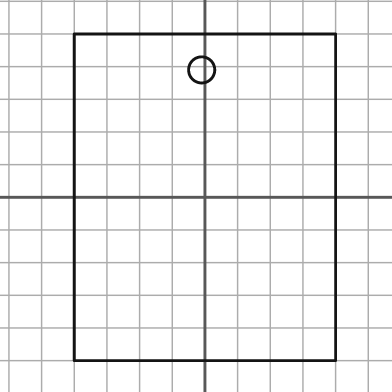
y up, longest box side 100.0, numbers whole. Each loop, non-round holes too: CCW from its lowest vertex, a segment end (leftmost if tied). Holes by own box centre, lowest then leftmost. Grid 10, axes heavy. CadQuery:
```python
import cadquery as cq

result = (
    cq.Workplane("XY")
    .moveTo(-40.0, -50.0)
    .lineTo(40.0, -50.0)
    .lineTo(40.0, 50.0)
    .lineTo(-40.0, 50.0)
    .close()
    .moveTo(-1.0, 39.0)
    .circle(4.0)
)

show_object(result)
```